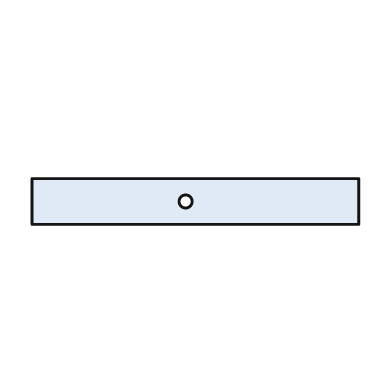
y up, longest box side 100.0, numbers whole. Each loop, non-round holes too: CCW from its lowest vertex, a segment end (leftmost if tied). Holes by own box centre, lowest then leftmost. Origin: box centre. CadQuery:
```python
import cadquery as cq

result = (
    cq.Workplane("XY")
    .moveTo(-50.0, -7.0)
    .lineTo(50.0, -7.0)
    .lineTo(50.0, 7.0)
    .lineTo(-50.0, 7.0)
    .close()
    .moveTo(-3.0, 0.0)
    .circle(2.0)
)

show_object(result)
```